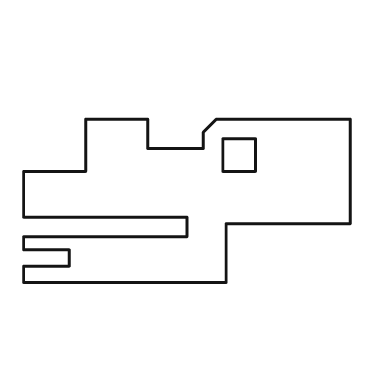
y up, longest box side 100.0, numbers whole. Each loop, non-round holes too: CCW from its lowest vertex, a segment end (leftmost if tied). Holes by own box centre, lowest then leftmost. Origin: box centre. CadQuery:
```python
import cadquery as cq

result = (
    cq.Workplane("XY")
    .moveTo(-50.0, -25.0)
    .lineTo(12.0, -25.0)
    .lineTo(12.0, -7.0)
    .lineTo(50.0, -7.0)
    .lineTo(50.0, 25.0)
    .lineTo(9.0, 25.0)
    .lineTo(5.0, 21.0)
    .lineTo(5.0, 16.0)
    .lineTo(-12.0, 16.0)
    .lineTo(-12.0, 25.0)
    .lineTo(-31.0, 25.0)
    .lineTo(-31.0, 9.0)
    .lineTo(-50.0, 9.0)
    .lineTo(-50.0, -5.0)
    .lineTo(0.0, -5.0)
    .lineTo(0.0, -11.0)
    .lineTo(-50.0, -11.0)
    .lineTo(-50.0, -15.0)
    .lineTo(-36.0, -15.0)
    .lineTo(-36.0, -20.0)
    .lineTo(-50.0, -20.0)
    .close()
    .moveTo(11.0, 9.0)
    .lineTo(21.0, 9.0)
    .lineTo(21.0, 19.0)
    .lineTo(11.0, 19.0)
    .close()
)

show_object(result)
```